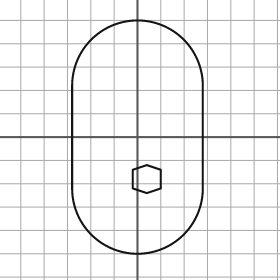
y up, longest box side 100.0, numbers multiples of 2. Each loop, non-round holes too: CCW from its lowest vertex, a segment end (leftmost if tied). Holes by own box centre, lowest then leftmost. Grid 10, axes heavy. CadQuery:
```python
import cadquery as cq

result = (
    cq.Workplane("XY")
    .moveTo(-28.0, -22.0)
    .threePointArc((0.0, -50.0), (28.0, -22.0))
    .lineTo(28.0, 22.0)
    .threePointArc((0.0, 50.0), (-28.0, 22.0))
    .close()
    .moveTo(4.0, -24.0)
    .lineTo(10.0, -22.0)
    .lineTo(10.0, -14.0)
    .lineTo(4.0, -12.0)
    .lineTo(-2.0, -14.0)
    .lineTo(-2.0, -22.0)
    .close()
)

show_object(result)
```